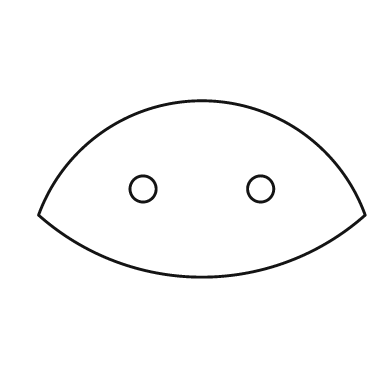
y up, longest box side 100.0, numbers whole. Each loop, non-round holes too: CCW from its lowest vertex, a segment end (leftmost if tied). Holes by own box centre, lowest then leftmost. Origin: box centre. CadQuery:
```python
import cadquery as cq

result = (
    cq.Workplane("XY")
    .moveTo(-50.0, -8.0)
    .threePointArc((0.0, -27.0), (50.0, -8.0))
    .threePointArc((0.0, 27.0), (-50.0, -8.0))
    .close()
    .moveTo(-18.0, 0.0)
    .circle(4.0)
    .moveTo(18.0, 0.0)
    .circle(4.0)
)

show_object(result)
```